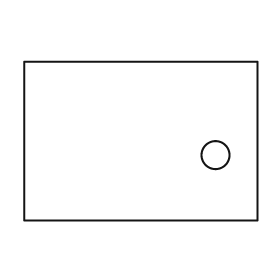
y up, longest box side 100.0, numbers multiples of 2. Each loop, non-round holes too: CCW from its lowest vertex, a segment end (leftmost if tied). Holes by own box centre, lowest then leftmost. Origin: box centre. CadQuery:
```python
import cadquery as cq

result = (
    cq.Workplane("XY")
    .moveTo(-50.0, -34.0)
    .lineTo(50.0, -34.0)
    .lineTo(50.0, 34.0)
    .lineTo(-50.0, 34.0)
    .close()
    .moveTo(32.0, -6.0)
    .circle(6.0)
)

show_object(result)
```